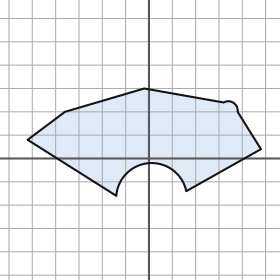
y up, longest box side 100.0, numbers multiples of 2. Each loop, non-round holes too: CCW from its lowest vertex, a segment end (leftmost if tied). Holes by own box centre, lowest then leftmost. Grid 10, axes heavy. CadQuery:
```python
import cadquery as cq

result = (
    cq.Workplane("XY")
    .moveTo(-14.0, -16.0)
    .threePointArc((0.0, -2.0), (16.0, -14.0))
    .lineTo(48.0, 4.0)
    .lineTo(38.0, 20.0)
    .threePointArc((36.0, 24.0), (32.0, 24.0))
    .lineTo(-2.0, 30.0)
    .lineTo(-36.0, 20.0)
    .lineTo(-52.0, 8.0)
    .close()
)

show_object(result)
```